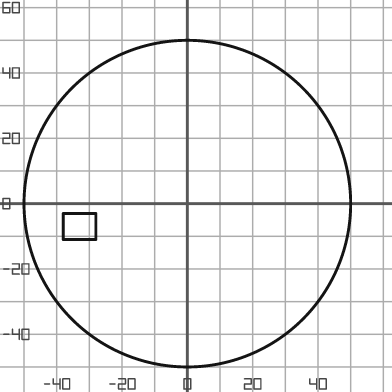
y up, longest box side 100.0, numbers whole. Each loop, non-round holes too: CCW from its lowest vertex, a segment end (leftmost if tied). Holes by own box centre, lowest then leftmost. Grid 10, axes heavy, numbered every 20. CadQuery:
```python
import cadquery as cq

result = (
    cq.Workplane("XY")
    .moveTo(0.0, 0.0)
    .circle(50.0)
    .moveTo(-38.0, -11.0)
    .lineTo(-28.0, -11.0)
    .lineTo(-28.0, -3.0)
    .lineTo(-38.0, -3.0)
    .close()
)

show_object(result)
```